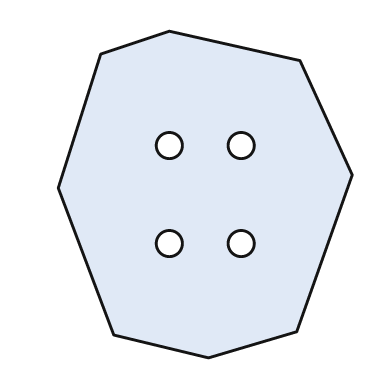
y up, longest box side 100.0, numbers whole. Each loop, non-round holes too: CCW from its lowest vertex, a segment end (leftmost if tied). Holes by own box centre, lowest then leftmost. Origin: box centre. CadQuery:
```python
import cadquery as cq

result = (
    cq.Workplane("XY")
    .moveTo(1.0, -50.0)
    .lineTo(28.0, -42.0)
    .lineTo(45.0, 6.0)
    .lineTo(29.0, 41.0)
    .lineTo(-11.0, 50.0)
    .lineTo(-32.0, 43.0)
    .lineTo(-45.0, 2.0)
    .lineTo(-28.0, -43.0)
    .close()
    .moveTo(-11.0, -15.0)
    .circle(4.0)
    .moveTo(11.0, -15.0)
    .circle(4.0)
    .moveTo(-11.0, 15.0)
    .circle(4.0)
    .moveTo(11.0, 15.0)
    .circle(4.0)
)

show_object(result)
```